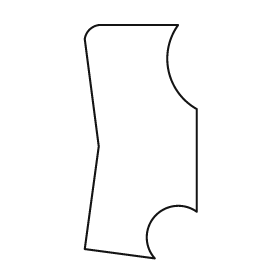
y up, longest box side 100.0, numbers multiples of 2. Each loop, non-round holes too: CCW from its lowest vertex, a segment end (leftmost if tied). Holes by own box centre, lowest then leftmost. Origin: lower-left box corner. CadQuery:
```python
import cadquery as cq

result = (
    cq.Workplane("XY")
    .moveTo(30.0, 0.0)
    .threePointArc((30.0, 18.0), (48.0, 20.0))
    .lineTo(48.0, 64.0)
    .threePointArc((36.0, 80.0), (40.0, 100.0))
    .lineTo(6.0, 100.0)
    .threePointArc((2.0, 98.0), (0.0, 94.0))
    .lineTo(6.0, 48.0)
    .lineTo(0.0, 4.0)
    .close()
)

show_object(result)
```